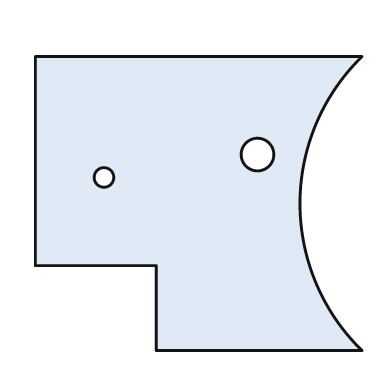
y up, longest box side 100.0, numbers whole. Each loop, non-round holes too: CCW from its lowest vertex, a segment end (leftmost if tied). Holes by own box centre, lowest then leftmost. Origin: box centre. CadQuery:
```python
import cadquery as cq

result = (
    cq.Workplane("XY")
    .moveTo(-13.0, -45.0)
    .lineTo(50.0, -45.0)
    .threePointArc((31.0, 0.0), (50.0, 45.0))
    .lineTo(-50.0, 45.0)
    .lineTo(-50.0, -19.0)
    .lineTo(-13.0, -19.0)
    .close()
    .moveTo(-29.0, 8.0)
    .circle(3.0)
    .moveTo(18.0, 15.0)
    .circle(5.0)
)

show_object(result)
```